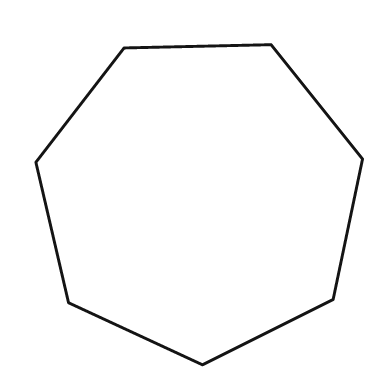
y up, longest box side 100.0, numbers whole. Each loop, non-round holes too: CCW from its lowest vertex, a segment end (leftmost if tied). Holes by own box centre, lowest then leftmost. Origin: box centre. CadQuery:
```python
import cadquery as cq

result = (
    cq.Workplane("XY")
    .moveTo(1.0, -49.0)
    .lineTo(41.0, -29.0)
    .lineTo(50.0, 14.0)
    .lineTo(22.0, 49.0)
    .lineTo(-23.0, 48.0)
    .lineTo(-50.0, 13.0)
    .lineTo(-40.0, -30.0)
    .close()
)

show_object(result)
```